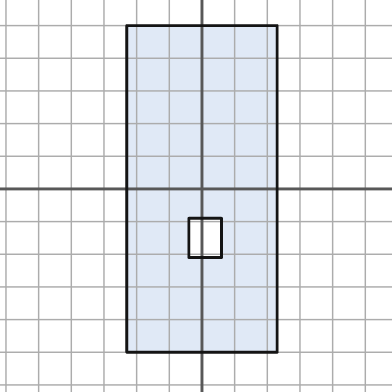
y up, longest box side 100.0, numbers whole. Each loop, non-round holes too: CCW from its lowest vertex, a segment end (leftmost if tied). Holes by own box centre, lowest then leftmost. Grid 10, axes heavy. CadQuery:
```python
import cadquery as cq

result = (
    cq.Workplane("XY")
    .moveTo(-23.0, -50.0)
    .lineTo(23.0, -50.0)
    .lineTo(23.0, 50.0)
    .lineTo(-23.0, 50.0)
    .close()
    .moveTo(-4.0, -21.0)
    .lineTo(6.0, -21.0)
    .lineTo(6.0, -9.0)
    .lineTo(-4.0, -9.0)
    .close()
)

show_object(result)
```